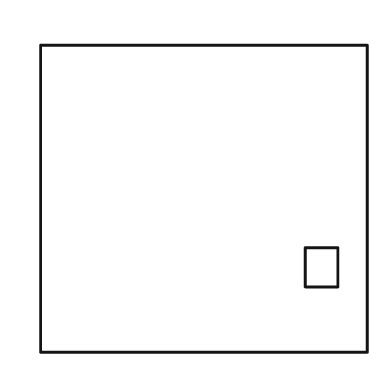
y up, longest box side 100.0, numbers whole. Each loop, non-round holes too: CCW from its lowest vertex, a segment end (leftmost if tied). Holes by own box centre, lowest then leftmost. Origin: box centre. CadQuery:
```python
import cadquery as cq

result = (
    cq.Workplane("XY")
    .moveTo(-50.0, -47.0)
    .lineTo(50.0, -47.0)
    .lineTo(50.0, 47.0)
    .lineTo(-50.0, 47.0)
    .close()
    .moveTo(31.0, -27.0)
    .lineTo(41.0, -27.0)
    .lineTo(41.0, -15.0)
    .lineTo(31.0, -15.0)
    .close()
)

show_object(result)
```